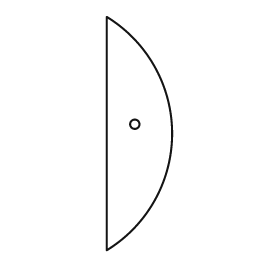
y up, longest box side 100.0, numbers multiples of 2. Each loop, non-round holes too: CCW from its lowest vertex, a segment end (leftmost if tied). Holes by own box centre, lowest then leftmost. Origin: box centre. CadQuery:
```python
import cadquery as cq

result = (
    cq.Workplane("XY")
    .moveTo(-14.0, -50.0)
    .threePointArc((14.0, 0.0), (-14.0, 50.0))
    .close()
    .moveTo(-2.0, 4.0)
    .circle(2.0)
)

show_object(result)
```